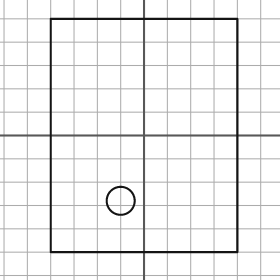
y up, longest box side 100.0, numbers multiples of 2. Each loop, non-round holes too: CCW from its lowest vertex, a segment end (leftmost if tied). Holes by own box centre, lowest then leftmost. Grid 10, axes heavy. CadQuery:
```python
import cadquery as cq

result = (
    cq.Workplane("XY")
    .moveTo(-40.0, -50.0)
    .lineTo(40.0, -50.0)
    .lineTo(40.0, 50.0)
    .lineTo(-40.0, 50.0)
    .close()
    .moveTo(-10.0, -28.0)
    .circle(6.0)
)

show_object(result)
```